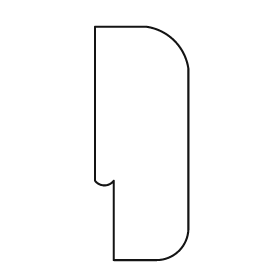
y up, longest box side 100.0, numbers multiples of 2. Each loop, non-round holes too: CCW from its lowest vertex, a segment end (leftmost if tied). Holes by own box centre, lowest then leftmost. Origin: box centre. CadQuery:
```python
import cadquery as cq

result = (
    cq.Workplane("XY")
    .moveTo(-12.0, -50.0)
    .lineTo(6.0, -50.0)
    .threePointArc((16.0, -46.0), (20.0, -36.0))
    .lineTo(20.0, 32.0)
    .threePointArc((14.0, 44.0), (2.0, 50.0))
    .lineTo(-20.0, 50.0)
    .lineTo(-20.0, -16.0)
    .threePointArc((-16.0, -18.0), (-12.0, -16.0))
    .close()
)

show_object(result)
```